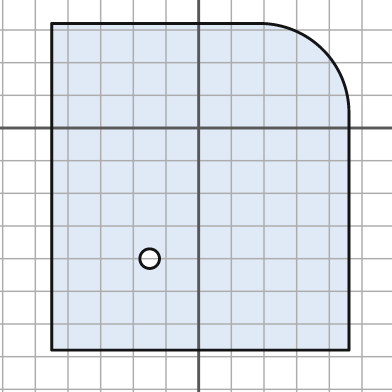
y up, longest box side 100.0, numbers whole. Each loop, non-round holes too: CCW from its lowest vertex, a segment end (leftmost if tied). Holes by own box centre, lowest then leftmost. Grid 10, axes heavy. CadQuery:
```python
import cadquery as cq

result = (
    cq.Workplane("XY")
    .moveTo(-45.0, -68.0)
    .lineTo(46.0, -68.0)
    .lineTo(46.0, 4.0)
    .threePointArc((38.0, 24.0), (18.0, 32.0))
    .lineTo(-45.0, 32.0)
    .close()
    .moveTo(-15.0, -40.0)
    .circle(3.0)
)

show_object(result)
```